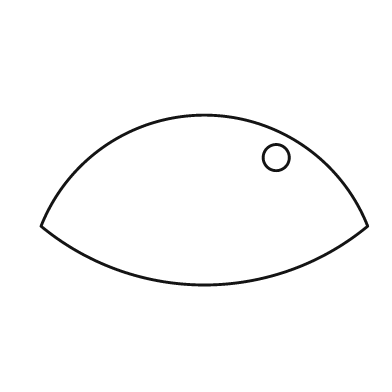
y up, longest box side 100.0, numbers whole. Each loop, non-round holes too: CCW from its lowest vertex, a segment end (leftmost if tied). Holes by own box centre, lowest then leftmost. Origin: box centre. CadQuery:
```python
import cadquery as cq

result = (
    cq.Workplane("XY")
    .moveTo(-50.0, -8.0)
    .threePointArc((0.0, -26.0), (50.0, -8.0))
    .threePointArc((0.0, 26.0), (-50.0, -8.0))
    .close()
    .moveTo(22.0, 13.0)
    .circle(4.0)
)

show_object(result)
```